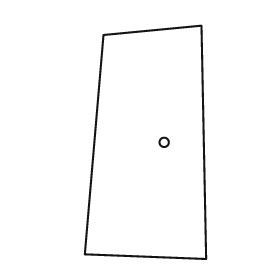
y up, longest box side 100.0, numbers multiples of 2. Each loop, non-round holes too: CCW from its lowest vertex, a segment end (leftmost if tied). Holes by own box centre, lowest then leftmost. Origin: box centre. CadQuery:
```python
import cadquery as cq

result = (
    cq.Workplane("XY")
    .moveTo(26.0, -50.0)
    .lineTo(24.0, 50.0)
    .lineTo(-18.0, 46.0)
    .lineTo(-26.0, -48.0)
    .close()
    .moveTo(8.0, 0.0)
    .circle(2.0)
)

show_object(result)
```